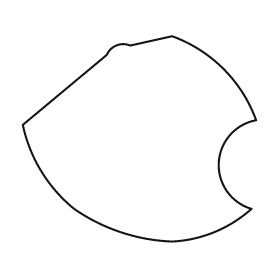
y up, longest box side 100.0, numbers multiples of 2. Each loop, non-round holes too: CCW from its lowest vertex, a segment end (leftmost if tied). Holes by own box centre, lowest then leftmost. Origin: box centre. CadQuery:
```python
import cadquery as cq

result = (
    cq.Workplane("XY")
    .moveTo(14.0, -44.0)
    .threePointArc((32.0, -40.0), (48.0, -30.0))
    .threePointArc((34.0, -10.0), (50.0, 8.0))
    .threePointArc((36.0, 30.0), (14.0, 44.0))
    .lineTo(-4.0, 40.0)
    .threePointArc((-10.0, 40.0), (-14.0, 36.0))
    .lineTo(-50.0, 6.0)
    .threePointArc((-42.0, -14.0), (-28.0, -30.0))
    .threePointArc((-8.0, -40.0), (14.0, -44.0))
    .close()
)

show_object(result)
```